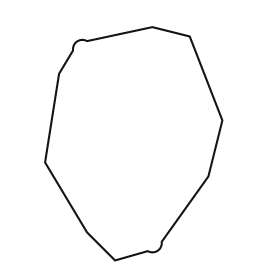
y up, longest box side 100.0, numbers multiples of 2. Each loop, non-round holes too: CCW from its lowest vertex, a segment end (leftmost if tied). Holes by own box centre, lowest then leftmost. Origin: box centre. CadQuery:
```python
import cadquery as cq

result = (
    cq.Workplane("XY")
    .moveTo(-8.0, -50.0)
    .lineTo(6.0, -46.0)
    .threePointArc((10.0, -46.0), (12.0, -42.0))
    .lineTo(32.0, -14.0)
    .lineTo(38.0, 10.0)
    .lineTo(24.0, 46.0)
    .lineTo(8.0, 50.0)
    .lineTo(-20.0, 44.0)
    .threePointArc((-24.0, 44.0), (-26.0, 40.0))
    .lineTo(-32.0, 30.0)
    .lineTo(-38.0, -8.0)
    .lineTo(-20.0, -38.0)
    .close()
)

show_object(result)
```